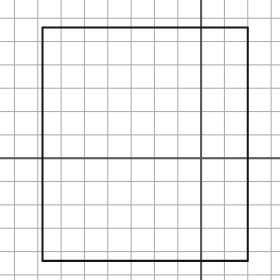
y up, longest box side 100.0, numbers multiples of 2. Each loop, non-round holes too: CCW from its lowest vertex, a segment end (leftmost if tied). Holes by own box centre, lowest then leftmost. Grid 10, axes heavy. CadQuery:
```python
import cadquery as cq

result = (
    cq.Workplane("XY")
    .moveTo(-68.0, -44.0)
    .lineTo(20.0, -44.0)
    .lineTo(20.0, 56.0)
    .lineTo(-68.0, 56.0)
    .close()
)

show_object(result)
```